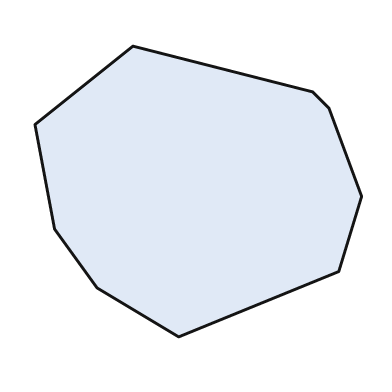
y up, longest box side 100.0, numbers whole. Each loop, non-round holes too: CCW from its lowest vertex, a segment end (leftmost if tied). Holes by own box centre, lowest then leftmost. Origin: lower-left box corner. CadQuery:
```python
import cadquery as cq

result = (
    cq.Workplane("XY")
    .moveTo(44.0, 0.0)
    .lineTo(93.0, 20.0)
    .lineTo(100.0, 43.0)
    .lineTo(90.0, 70.0)
    .lineTo(85.0, 75.0)
    .lineTo(30.0, 89.0)
    .lineTo(0.0, 65.0)
    .lineTo(6.0, 33.0)
    .lineTo(19.0, 15.0)
    .close()
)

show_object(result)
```